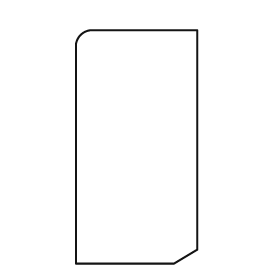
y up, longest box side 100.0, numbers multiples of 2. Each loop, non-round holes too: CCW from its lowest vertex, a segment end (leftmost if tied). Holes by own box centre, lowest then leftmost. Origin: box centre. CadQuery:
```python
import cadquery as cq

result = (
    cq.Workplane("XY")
    .moveTo(-26.0, -50.0)
    .lineTo(16.0, -50.0)
    .lineTo(26.0, -44.0)
    .lineTo(26.0, 50.0)
    .lineTo(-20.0, 50.0)
    .threePointArc((-24.0, 48.0), (-26.0, 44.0))
    .close()
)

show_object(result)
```